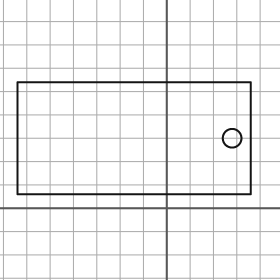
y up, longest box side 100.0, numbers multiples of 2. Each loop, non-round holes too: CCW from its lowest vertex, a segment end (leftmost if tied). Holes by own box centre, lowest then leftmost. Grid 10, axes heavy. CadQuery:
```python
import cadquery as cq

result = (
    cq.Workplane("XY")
    .moveTo(-64.0, 6.0)
    .lineTo(36.0, 6.0)
    .lineTo(36.0, 54.0)
    .lineTo(-64.0, 54.0)
    .close()
    .moveTo(28.0, 30.0)
    .circle(4.0)
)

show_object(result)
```